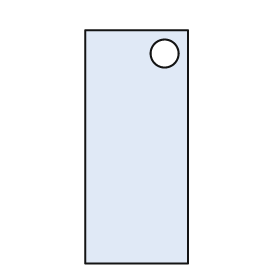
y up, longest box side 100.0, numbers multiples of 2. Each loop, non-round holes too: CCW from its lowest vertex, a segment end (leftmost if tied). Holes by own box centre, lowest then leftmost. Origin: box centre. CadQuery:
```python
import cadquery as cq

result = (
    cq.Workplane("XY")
    .moveTo(-22.0, -50.0)
    .lineTo(22.0, -50.0)
    .lineTo(22.0, 50.0)
    .lineTo(-22.0, 50.0)
    .close()
    .moveTo(12.0, 40.0)
    .circle(6.0)
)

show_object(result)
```